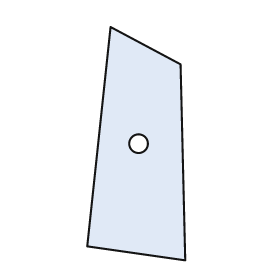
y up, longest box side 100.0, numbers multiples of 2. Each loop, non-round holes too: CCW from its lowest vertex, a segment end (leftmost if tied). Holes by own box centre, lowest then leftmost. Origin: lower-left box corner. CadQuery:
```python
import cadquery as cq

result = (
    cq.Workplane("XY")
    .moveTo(42.0, 0.0)
    .lineTo(40.0, 84.0)
    .lineTo(10.0, 100.0)
    .lineTo(0.0, 6.0)
    .close()
    .moveTo(22.0, 50.0)
    .circle(4.0)
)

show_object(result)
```